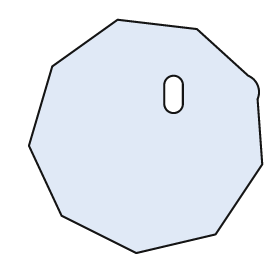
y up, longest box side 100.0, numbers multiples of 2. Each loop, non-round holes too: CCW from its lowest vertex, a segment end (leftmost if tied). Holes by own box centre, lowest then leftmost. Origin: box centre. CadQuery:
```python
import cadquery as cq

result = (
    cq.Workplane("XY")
    .moveTo(-4.0, -50.0)
    .lineTo(30.0, -42.0)
    .lineTo(50.0, -12.0)
    .lineTo(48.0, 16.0)
    .threePointArc((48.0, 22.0), (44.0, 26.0))
    .lineTo(22.0, 46.0)
    .lineTo(-12.0, 50.0)
    .lineTo(-40.0, 30.0)
    .lineTo(-50.0, -4.0)
    .lineTo(-36.0, -34.0)
    .close()
    .moveTo(8.0, 14.0)
    .threePointArc((12.0, 10.0), (16.0, 14.0))
    .lineTo(16.0, 22.0)
    .threePointArc((12.0, 26.0), (8.0, 22.0))
    .close()
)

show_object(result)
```